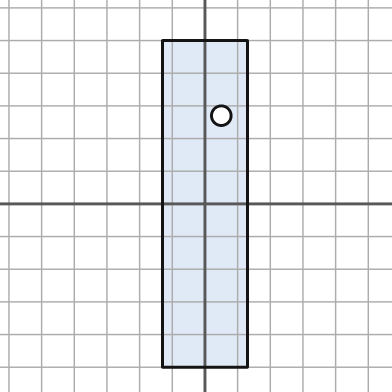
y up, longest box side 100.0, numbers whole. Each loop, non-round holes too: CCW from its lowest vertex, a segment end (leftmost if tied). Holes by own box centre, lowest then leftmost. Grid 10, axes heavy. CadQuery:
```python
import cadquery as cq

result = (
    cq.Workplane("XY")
    .moveTo(-13.0, -50.0)
    .lineTo(13.0, -50.0)
    .lineTo(13.0, 50.0)
    .lineTo(-13.0, 50.0)
    .close()
    .moveTo(5.0, 27.0)
    .circle(3.0)
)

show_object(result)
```